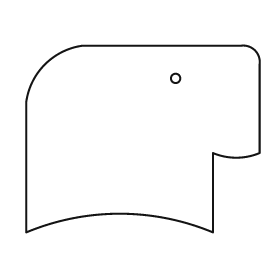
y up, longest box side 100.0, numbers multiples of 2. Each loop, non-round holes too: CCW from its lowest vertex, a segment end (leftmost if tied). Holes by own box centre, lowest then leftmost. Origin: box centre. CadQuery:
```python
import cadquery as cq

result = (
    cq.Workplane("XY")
    .moveTo(-50.0, -40.0)
    .threePointArc((-10.0, -32.0), (30.0, -40.0))
    .lineTo(30.0, -6.0)
    .threePointArc((40.0, -8.0), (50.0, -6.0))
    .lineTo(50.0, 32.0)
    .threePointArc((48.0, 38.0), (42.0, 40.0))
    .lineTo(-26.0, 40.0)
    .threePointArc((-42.0, 32.0), (-50.0, 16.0))
    .close()
    .moveTo(14.0, 26.0)
    .circle(2.0)
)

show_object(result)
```